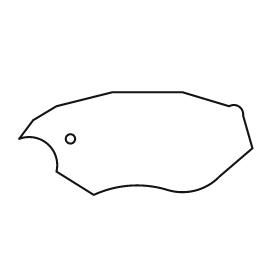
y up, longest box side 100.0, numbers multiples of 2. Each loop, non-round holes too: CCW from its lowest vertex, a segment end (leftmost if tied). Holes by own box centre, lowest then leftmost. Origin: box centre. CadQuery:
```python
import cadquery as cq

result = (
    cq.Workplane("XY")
    .moveTo(-18.0, -22.0)
    .threePointArc((-2.0, -18.0), (14.0, -20.0))
    .threePointArc((26.0, -20.0), (36.0, -14.0))
    .lineTo(50.0, -2.0)
    .lineTo(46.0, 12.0)
    .threePointArc((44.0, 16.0), (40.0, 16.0))
    .lineTo(20.0, 22.0)
    .lineTo(-10.0, 22.0)
    .lineTo(-34.0, 16.0)
    .lineTo(-44.0, 10.0)
    .lineTo(-50.0, 2.0)
    .threePointArc((-38.0, 0.0), (-34.0, -12.0))
    .close()
    .moveTo(-28.0, 2.0)
    .circle(2.0)
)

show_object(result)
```